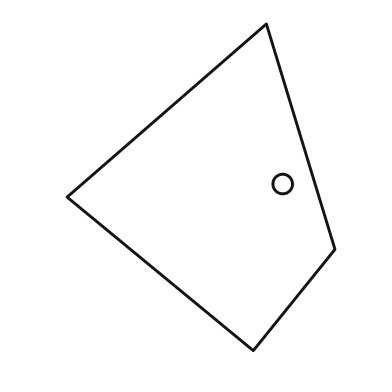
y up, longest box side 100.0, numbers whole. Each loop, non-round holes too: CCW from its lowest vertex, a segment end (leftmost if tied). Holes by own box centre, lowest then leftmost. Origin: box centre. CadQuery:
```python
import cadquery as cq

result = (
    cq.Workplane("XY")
    .moveTo(16.0, -50.0)
    .lineTo(41.0, -19.0)
    .lineTo(20.0, 50.0)
    .lineTo(-41.0, -3.0)
    .close()
    .moveTo(25.0, 1.0)
    .circle(3.0)
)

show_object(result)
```